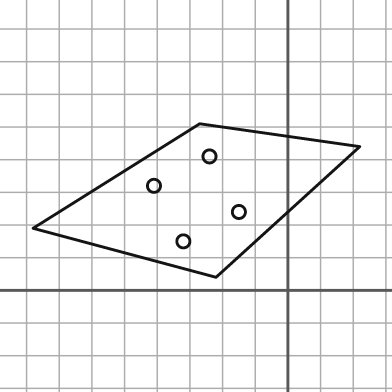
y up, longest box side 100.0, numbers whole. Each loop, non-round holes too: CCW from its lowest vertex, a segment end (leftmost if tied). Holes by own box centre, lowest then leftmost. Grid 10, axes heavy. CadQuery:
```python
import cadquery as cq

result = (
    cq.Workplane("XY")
    .moveTo(-22.0, 4.0)
    .lineTo(22.0, 44.0)
    .lineTo(-27.0, 51.0)
    .lineTo(-78.0, 19.0)
    .close()
    .moveTo(-32.0, 15.0)
    .circle(2.0)
    .moveTo(-15.0, 24.0)
    .circle(2.0)
    .moveTo(-41.0, 32.0)
    .circle(2.0)
    .moveTo(-24.0, 41.0)
    .circle(2.0)
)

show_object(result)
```